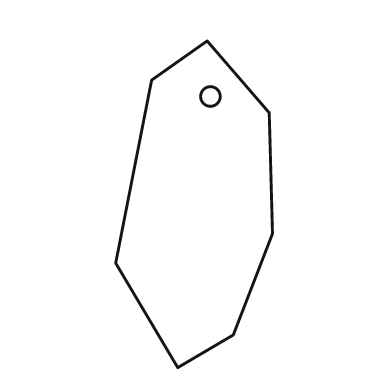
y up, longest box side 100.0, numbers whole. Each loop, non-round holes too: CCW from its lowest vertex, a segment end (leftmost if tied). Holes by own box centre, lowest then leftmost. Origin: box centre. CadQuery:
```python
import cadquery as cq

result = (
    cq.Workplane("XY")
    .moveTo(-5.0, -50.0)
    .lineTo(12.0, -40.0)
    .lineTo(24.0, -9.0)
    .lineTo(23.0, 28.0)
    .lineTo(4.0, 50.0)
    .lineTo(-13.0, 38.0)
    .lineTo(-24.0, -18.0)
    .close()
    .moveTo(5.0, 33.0)
    .circle(3.0)
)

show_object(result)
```